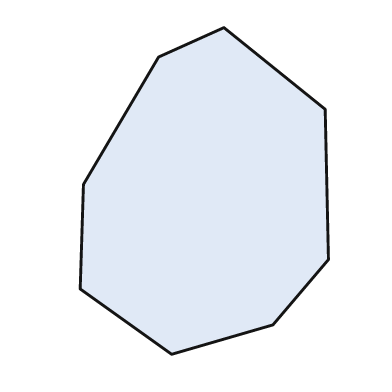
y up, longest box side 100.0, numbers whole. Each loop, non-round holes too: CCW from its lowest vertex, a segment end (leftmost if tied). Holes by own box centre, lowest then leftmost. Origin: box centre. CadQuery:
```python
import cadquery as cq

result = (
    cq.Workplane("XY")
    .moveTo(-10.0, -50.0)
    .lineTo(21.0, -41.0)
    .lineTo(38.0, -21.0)
    .lineTo(37.0, 25.0)
    .lineTo(6.0, 50.0)
    .lineTo(-14.0, 41.0)
    .lineTo(-37.0, 2.0)
    .lineTo(-38.0, -30.0)
    .close()
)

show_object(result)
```